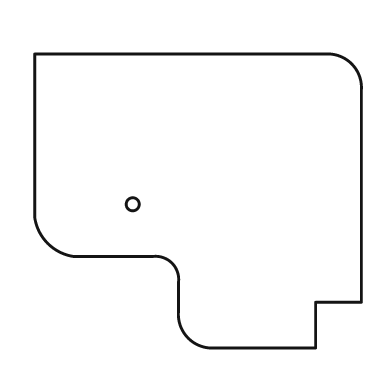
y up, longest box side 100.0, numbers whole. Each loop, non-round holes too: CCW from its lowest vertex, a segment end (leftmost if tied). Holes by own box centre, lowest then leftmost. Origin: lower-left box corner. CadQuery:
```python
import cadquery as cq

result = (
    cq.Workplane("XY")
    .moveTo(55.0, 0.0)
    .lineTo(86.0, 0.0)
    .lineTo(86.0, 14.0)
    .lineTo(100.0, 14.0)
    .lineTo(100.0, 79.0)
    .threePointArc((97.0, 87.0), (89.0, 90.0))
    .lineTo(0.0, 90.0)
    .lineTo(0.0, 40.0)
    .threePointArc((4.0, 32.0), (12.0, 28.0))
    .lineTo(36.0, 28.0)
    .threePointArc((42.0, 26.0), (44.0, 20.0))
    .lineTo(44.0, 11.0)
    .threePointArc((47.0, 3.0), (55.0, 0.0))
    .close()
    .moveTo(30.0, 44.0)
    .circle(2.0)
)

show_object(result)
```